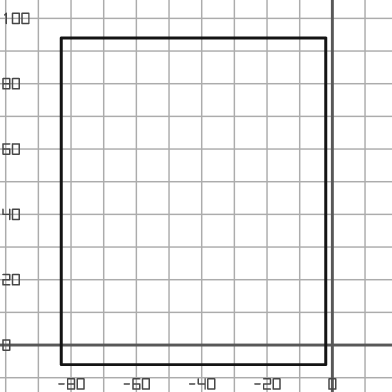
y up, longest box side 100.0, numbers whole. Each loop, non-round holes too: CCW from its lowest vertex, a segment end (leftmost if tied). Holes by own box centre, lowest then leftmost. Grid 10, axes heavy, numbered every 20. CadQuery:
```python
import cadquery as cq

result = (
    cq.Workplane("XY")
    .moveTo(-83.0, -6.0)
    .lineTo(-2.0, -6.0)
    .lineTo(-2.0, 94.0)
    .lineTo(-83.0, 94.0)
    .close()
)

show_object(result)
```